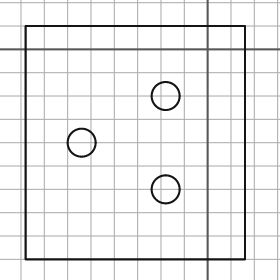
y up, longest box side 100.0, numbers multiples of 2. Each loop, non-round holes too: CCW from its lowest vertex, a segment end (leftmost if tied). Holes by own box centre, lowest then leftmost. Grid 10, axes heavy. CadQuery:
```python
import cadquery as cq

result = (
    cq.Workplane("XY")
    .moveTo(-78.0, -90.0)
    .lineTo(16.0, -90.0)
    .lineTo(16.0, 10.0)
    .lineTo(-78.0, 10.0)
    .close()
    .moveTo(-18.0, -60.0)
    .circle(6.0)
    .moveTo(-54.0, -40.0)
    .circle(6.0)
    .moveTo(-18.0, -20.0)
    .circle(6.0)
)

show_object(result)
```